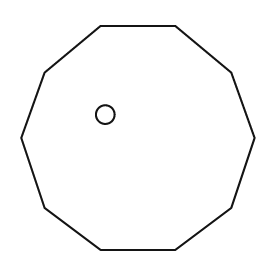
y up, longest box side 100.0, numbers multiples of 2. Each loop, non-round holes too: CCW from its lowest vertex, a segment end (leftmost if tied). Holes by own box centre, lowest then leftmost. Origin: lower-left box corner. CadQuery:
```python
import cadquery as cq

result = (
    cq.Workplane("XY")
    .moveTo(34.0, 0.0)
    .lineTo(66.0, 0.0)
    .lineTo(90.0, 18.0)
    .lineTo(100.0, 48.0)
    .lineTo(90.0, 76.0)
    .lineTo(66.0, 96.0)
    .lineTo(34.0, 96.0)
    .lineTo(10.0, 76.0)
    .lineTo(0.0, 48.0)
    .lineTo(10.0, 18.0)
    .close()
    .moveTo(36.0, 58.0)
    .circle(4.0)
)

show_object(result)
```